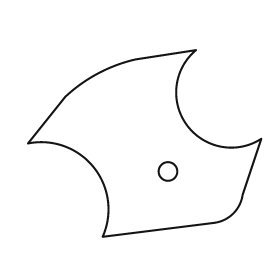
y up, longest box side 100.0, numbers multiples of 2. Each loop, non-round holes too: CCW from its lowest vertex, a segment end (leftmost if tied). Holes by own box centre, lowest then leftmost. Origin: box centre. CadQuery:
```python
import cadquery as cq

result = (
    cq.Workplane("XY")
    .moveTo(-18.0, -40.0)
    .lineTo(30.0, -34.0)
    .threePointArc((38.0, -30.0), (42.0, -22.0))
    .lineTo(50.0, 2.0)
    .threePointArc((18.0, 8.0), (22.0, 40.0))
    .lineTo(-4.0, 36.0)
    .threePointArc((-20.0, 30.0), (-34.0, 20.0))
    .lineTo(-50.0, 0.0)
    .threePointArc((-22.0, -10.0), (-18.0, -40.0))
    .close()
    .moveTo(10.0, -12.0)
    .circle(4.0)
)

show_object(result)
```